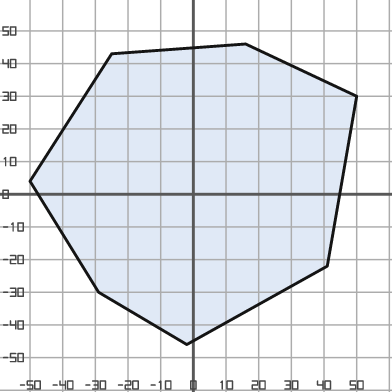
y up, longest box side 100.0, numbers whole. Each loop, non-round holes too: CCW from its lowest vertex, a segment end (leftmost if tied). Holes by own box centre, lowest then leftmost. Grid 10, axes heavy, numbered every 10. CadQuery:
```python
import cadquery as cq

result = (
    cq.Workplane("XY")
    .moveTo(-2.0, -46.0)
    .lineTo(41.0, -22.0)
    .lineTo(50.0, 30.0)
    .lineTo(16.0, 46.0)
    .lineTo(-25.0, 43.0)
    .lineTo(-50.0, 4.0)
    .lineTo(-29.0, -30.0)
    .close()
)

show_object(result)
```